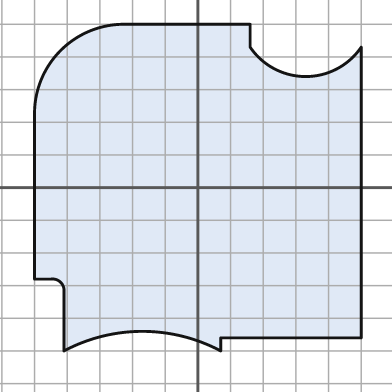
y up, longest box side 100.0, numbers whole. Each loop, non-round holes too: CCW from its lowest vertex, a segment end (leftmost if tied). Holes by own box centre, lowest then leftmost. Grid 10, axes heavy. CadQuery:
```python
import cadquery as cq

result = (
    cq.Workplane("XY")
    .moveTo(-41.0, -50.0)
    .threePointArc((-17.0, -44.0), (7.0, -50.0))
    .lineTo(7.0, -46.0)
    .lineTo(50.0, -46.0)
    .lineTo(50.0, 43.0)
    .threePointArc((33.0, 34.0), (16.0, 43.0))
    .lineTo(16.0, 50.0)
    .lineTo(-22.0, 50.0)
    .threePointArc((-42.0, 42.0), (-50.0, 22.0))
    .lineTo(-50.0, -28.0)
    .lineTo(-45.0, -28.0)
    .threePointArc((-42.0, -29.0), (-41.0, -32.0))
    .close()
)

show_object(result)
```